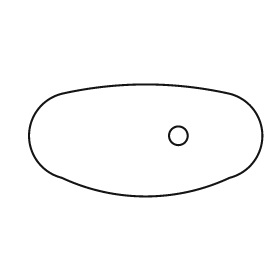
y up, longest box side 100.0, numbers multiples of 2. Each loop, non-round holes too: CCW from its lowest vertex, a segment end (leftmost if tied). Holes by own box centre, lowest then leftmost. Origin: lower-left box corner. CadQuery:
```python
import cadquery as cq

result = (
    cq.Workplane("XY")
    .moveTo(14.0, 8.0)
    .threePointArc((50.0, 0.0), (86.0, 8.0))
    .threePointArc((100.0, 26.0), (86.0, 44.0))
    .threePointArc((50.0, 48.0), (14.0, 44.0))
    .threePointArc((0.0, 26.0), (14.0, 8.0))
    .close()
    .moveTo(64.0, 26.0)
    .circle(4.0)
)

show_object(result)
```